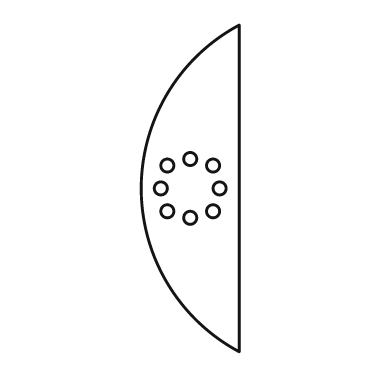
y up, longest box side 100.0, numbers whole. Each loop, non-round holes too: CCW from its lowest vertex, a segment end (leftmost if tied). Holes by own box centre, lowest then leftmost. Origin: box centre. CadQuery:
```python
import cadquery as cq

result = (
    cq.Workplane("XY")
    .moveTo(15.0, -50.0)
    .lineTo(15.0, 50.0)
    .threePointArc((-15.0, 0.0), (15.0, -50.0))
    .close()
    .moveTo(0.0, -9.0)
    .circle(2.0)
    .moveTo(-7.0, -7.0)
    .circle(2.0)
    .moveTo(7.0, -7.0)
    .circle(2.0)
    .moveTo(-9.0, 0.0)
    .circle(2.0)
    .moveTo(9.0, 0.0)
    .circle(2.0)
    .moveTo(-7.0, 7.0)
    .circle(2.0)
    .moveTo(7.0, 7.0)
    .circle(2.0)
    .moveTo(0.0, 9.0)
    .circle(2.0)
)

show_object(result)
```